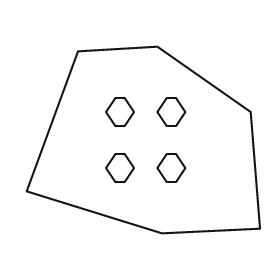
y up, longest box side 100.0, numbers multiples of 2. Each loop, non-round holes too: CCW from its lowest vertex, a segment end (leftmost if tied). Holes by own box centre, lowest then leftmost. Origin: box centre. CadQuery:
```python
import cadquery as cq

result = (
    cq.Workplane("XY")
    .moveTo(8.0, -40.0)
    .lineTo(50.0, -38.0)
    .lineTo(46.0, 12.0)
    .lineTo(6.0, 40.0)
    .lineTo(-28.0, 38.0)
    .lineTo(-50.0, -22.0)
    .close()
    .moveTo(-12.0, -18.0)
    .lineTo(-8.0, -18.0)
    .lineTo(-4.0, -12.0)
    .lineTo(-8.0, -6.0)
    .lineTo(-12.0, -6.0)
    .lineTo(-16.0, -12.0)
    .close()
    .moveTo(10.0, -18.0)
    .lineTo(14.0, -18.0)
    .lineTo(18.0, -12.0)
    .lineTo(14.0, -6.0)
    .lineTo(10.0, -6.0)
    .lineTo(6.0, -12.0)
    .close()
    .moveTo(-12.0, 6.0)
    .lineTo(-8.0, 6.0)
    .lineTo(-4.0, 12.0)
    .lineTo(-8.0, 18.0)
    .lineTo(-12.0, 18.0)
    .lineTo(-16.0, 12.0)
    .close()
    .moveTo(10.0, 6.0)
    .lineTo(14.0, 6.0)
    .lineTo(18.0, 12.0)
    .lineTo(14.0, 18.0)
    .lineTo(10.0, 18.0)
    .lineTo(6.0, 12.0)
    .close()
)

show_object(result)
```